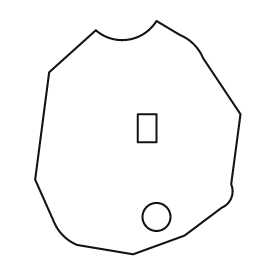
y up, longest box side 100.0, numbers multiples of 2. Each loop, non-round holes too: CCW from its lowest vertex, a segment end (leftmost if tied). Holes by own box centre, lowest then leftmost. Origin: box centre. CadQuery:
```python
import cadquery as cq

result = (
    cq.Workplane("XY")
    .moveTo(-2.0, -50.0)
    .lineTo(20.0, -42.0)
    .lineTo(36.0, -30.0)
    .threePointArc((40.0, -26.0), (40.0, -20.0))
    .lineTo(44.0, 10.0)
    .lineTo(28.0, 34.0)
    .threePointArc((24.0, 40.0), (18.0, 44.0))
    .lineTo(8.0, 50.0)
    .threePointArc((-4.0, 42.0), (-18.0, 46.0))
    .lineTo(-38.0, 28.0)
    .lineTo(-44.0, -18.0)
    .lineTo(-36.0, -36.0)
    .threePointArc((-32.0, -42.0), (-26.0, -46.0))
    .close()
    .moveTo(8.0, -34.0)
    .circle(6.0)
    .moveTo(0.0, -2.0)
    .lineTo(8.0, -2.0)
    .lineTo(8.0, 10.0)
    .lineTo(0.0, 10.0)
    .close()
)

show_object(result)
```